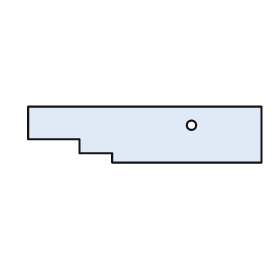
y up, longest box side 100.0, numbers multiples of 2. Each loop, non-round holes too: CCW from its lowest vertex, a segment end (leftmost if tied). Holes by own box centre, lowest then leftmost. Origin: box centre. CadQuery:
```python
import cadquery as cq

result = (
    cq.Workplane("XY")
    .moveTo(-14.0, -12.0)
    .lineTo(50.0, -12.0)
    .lineTo(50.0, 12.0)
    .lineTo(-50.0, 12.0)
    .lineTo(-50.0, -2.0)
    .lineTo(-28.0, -2.0)
    .lineTo(-28.0, -8.0)
    .lineTo(-14.0, -8.0)
    .close()
    .moveTo(20.0, 4.0)
    .circle(2.0)
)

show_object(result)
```